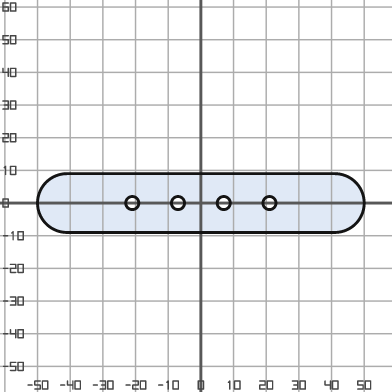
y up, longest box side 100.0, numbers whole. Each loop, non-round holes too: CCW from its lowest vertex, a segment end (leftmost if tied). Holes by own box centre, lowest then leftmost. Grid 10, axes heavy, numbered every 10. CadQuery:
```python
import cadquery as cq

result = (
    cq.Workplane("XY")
    .moveTo(-41.0, -9.0)
    .lineTo(41.0, -9.0)
    .threePointArc((50.0, 0.0), (41.0, 9.0))
    .lineTo(-41.0, 9.0)
    .threePointArc((-50.0, 0.0), (-41.0, -9.0))
    .close()
    .moveTo(-21.0, 0.0)
    .circle(2.0)
    .moveTo(-7.0, 0.0)
    .circle(2.0)
    .moveTo(7.0, 0.0)
    .circle(2.0)
    .moveTo(21.0, 0.0)
    .circle(2.0)
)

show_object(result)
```